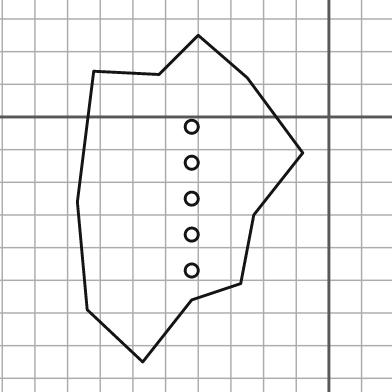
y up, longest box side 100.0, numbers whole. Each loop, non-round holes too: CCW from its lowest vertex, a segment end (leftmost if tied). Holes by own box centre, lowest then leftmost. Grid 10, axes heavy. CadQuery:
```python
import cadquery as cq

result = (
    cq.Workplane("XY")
    .moveTo(-57.0, -75.0)
    .lineTo(-42.0, -56.0)
    .lineTo(-27.0, -51.0)
    .lineTo(-23.0, -30.0)
    .lineTo(-8.0, -11.0)
    .lineTo(-25.0, 12.0)
    .lineTo(-40.0, 25.0)
    .lineTo(-52.0, 13.0)
    .lineTo(-72.0, 14.0)
    .lineTo(-77.0, -26.0)
    .lineTo(-74.0, -59.0)
    .close()
    .moveTo(-42.0, -47.0)
    .circle(2.0)
    .moveTo(-42.0, -36.0)
    .circle(2.0)
    .moveTo(-42.0, -25.0)
    .circle(2.0)
    .moveTo(-42.0, -14.0)
    .circle(2.0)
    .moveTo(-42.0, -3.0)
    .circle(2.0)
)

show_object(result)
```